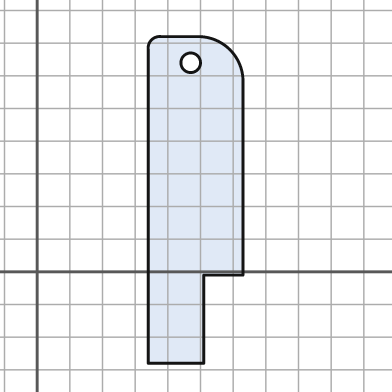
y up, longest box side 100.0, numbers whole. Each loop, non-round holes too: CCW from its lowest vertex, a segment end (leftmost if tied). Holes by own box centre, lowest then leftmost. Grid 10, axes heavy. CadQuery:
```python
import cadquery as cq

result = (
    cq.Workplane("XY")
    .moveTo(34.0, -28.0)
    .lineTo(51.0, -28.0)
    .lineTo(51.0, -1.0)
    .lineTo(63.0, -1.0)
    .lineTo(63.0, 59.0)
    .threePointArc((59.0, 68.0), (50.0, 72.0))
    .lineTo(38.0, 72.0)
    .threePointArc((35.0, 71.0), (34.0, 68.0))
    .close()
    .moveTo(47.0, 64.0)
    .circle(3.0)
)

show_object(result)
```